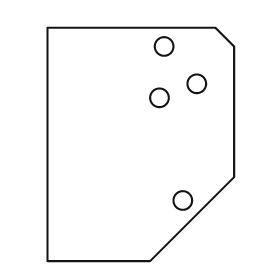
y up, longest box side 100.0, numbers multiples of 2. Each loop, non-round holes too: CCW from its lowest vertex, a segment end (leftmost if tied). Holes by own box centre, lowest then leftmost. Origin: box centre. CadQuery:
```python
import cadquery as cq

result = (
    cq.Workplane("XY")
    .moveTo(-40.0, -50.0)
    .lineTo(4.0, -50.0)
    .lineTo(40.0, -14.0)
    .lineTo(40.0, 42.0)
    .lineTo(32.0, 50.0)
    .lineTo(-40.0, 50.0)
    .close()
    .moveTo(18.0, -24.0)
    .circle(4.0)
    .moveTo(8.0, 20.0)
    .circle(4.0)
    .moveTo(24.0, 26.0)
    .circle(4.0)
    .moveTo(10.0, 42.0)
    .circle(4.0)
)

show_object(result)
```